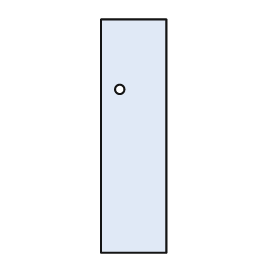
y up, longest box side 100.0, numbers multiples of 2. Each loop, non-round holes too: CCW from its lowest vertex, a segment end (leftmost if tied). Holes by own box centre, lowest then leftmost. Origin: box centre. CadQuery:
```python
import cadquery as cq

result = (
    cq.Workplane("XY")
    .moveTo(-14.0, -50.0)
    .lineTo(14.0, -50.0)
    .lineTo(14.0, 50.0)
    .lineTo(-14.0, 50.0)
    .close()
    .moveTo(-6.0, 20.0)
    .circle(2.0)
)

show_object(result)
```